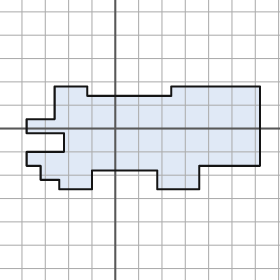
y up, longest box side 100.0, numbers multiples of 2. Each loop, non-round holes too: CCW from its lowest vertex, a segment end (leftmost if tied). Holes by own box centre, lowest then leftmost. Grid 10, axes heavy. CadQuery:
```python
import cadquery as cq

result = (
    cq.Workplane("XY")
    .moveTo(-24.0, -26.0)
    .lineTo(-10.0, -26.0)
    .lineTo(-10.0, -18.0)
    .lineTo(18.0, -18.0)
    .lineTo(18.0, -26.0)
    .lineTo(36.0, -26.0)
    .lineTo(36.0, -16.0)
    .lineTo(62.0, -16.0)
    .lineTo(62.0, 18.0)
    .lineTo(24.0, 18.0)
    .lineTo(24.0, 14.0)
    .lineTo(-12.0, 14.0)
    .lineTo(-12.0, 18.0)
    .lineTo(-26.0, 18.0)
    .lineTo(-26.0, 4.0)
    .lineTo(-38.0, 4.0)
    .lineTo(-38.0, -2.0)
    .lineTo(-22.0, -2.0)
    .lineTo(-22.0, -10.0)
    .lineTo(-38.0, -10.0)
    .lineTo(-38.0, -16.0)
    .lineTo(-32.0, -16.0)
    .lineTo(-32.0, -22.0)
    .lineTo(-24.0, -22.0)
    .close()
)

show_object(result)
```